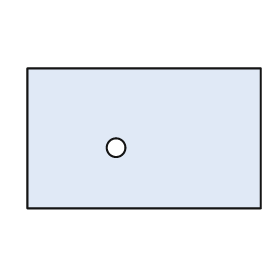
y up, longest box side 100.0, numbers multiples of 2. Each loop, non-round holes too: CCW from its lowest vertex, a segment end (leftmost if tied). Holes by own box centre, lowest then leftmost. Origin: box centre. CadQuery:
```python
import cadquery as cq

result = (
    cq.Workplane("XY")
    .moveTo(-50.0, -30.0)
    .lineTo(50.0, -30.0)
    .lineTo(50.0, 30.0)
    .lineTo(-50.0, 30.0)
    .close()
    .moveTo(-12.0, -4.0)
    .circle(4.0)
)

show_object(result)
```